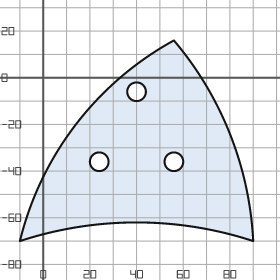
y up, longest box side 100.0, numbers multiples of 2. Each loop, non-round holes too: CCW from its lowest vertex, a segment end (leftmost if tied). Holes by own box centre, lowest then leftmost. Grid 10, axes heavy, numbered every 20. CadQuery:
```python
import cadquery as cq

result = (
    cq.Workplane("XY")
    .moveTo(-10.0, -70.0)
    .threePointArc((40.0, -62.0), (90.0, -70.0))
    .threePointArc((80.0, -24.0), (56.0, 16.0))
    .threePointArc((14.0, -20.0), (-10.0, -70.0))
    .close()
    .moveTo(24.0, -36.0)
    .circle(4.0)
    .moveTo(56.0, -36.0)
    .circle(4.0)
    .moveTo(40.0, -6.0)
    .circle(4.0)
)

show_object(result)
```